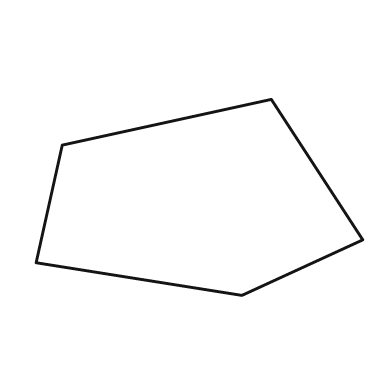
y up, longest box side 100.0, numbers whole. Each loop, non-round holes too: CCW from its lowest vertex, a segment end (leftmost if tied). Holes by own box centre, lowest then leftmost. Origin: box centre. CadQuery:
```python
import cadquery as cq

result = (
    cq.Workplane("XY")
    .moveTo(13.0, -30.0)
    .lineTo(50.0, -13.0)
    .lineTo(22.0, 30.0)
    .lineTo(-42.0, 16.0)
    .lineTo(-50.0, -20.0)
    .close()
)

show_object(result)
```